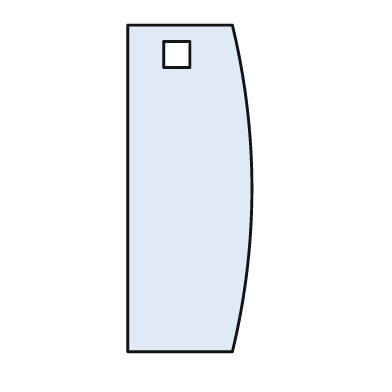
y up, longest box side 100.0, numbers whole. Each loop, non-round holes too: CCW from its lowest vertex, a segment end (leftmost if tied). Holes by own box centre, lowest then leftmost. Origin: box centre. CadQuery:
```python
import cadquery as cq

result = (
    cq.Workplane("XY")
    .moveTo(-19.0, -50.0)
    .lineTo(13.0, -50.0)
    .threePointArc((19.0, 0.0), (13.0, 50.0))
    .lineTo(-19.0, 50.0)
    .close()
    .moveTo(-8.0, 37.0)
    .lineTo(0.0, 37.0)
    .lineTo(0.0, 45.0)
    .lineTo(-8.0, 45.0)
    .close()
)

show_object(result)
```